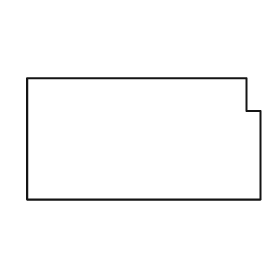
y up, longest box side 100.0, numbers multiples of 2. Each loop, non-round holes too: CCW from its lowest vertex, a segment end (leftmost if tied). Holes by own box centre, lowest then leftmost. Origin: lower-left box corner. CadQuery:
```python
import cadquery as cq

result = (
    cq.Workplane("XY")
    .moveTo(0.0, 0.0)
    .lineTo(100.0, 0.0)
    .lineTo(100.0, 38.0)
    .lineTo(94.0, 38.0)
    .lineTo(94.0, 52.0)
    .lineTo(0.0, 52.0)
    .close()
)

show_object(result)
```